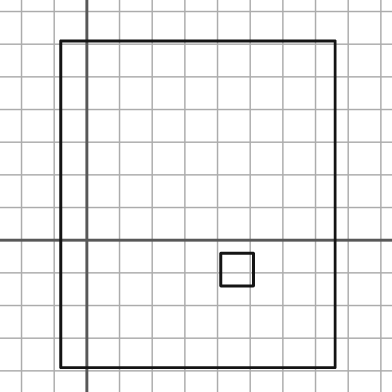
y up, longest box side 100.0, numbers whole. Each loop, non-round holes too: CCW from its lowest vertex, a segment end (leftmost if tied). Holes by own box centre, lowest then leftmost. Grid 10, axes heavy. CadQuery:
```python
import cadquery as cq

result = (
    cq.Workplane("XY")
    .moveTo(-8.0, -39.0)
    .lineTo(76.0, -39.0)
    .lineTo(76.0, 61.0)
    .lineTo(-8.0, 61.0)
    .close()
    .moveTo(41.0, -14.0)
    .lineTo(51.0, -14.0)
    .lineTo(51.0, -4.0)
    .lineTo(41.0, -4.0)
    .close()
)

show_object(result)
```